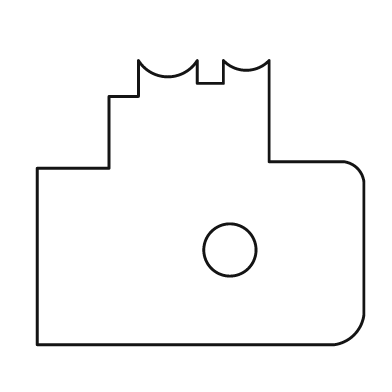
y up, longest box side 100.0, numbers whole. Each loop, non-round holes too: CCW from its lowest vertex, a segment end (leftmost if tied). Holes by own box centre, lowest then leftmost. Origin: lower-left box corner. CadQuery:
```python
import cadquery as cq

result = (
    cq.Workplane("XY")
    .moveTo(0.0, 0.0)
    .lineTo(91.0, 0.0)
    .threePointArc((97.0, 3.0), (100.0, 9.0))
    .lineTo(100.0, 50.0)
    .threePointArc((98.0, 54.0), (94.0, 56.0))
    .lineTo(71.0, 56.0)
    .lineTo(71.0, 87.0)
    .threePointArc((64.0, 84.0), (57.0, 87.0))
    .lineTo(57.0, 80.0)
    .lineTo(49.0, 80.0)
    .lineTo(49.0, 87.0)
    .threePointArc((40.0, 82.0), (31.0, 87.0))
    .lineTo(31.0, 76.0)
    .lineTo(22.0, 76.0)
    .lineTo(22.0, 54.0)
    .lineTo(0.0, 54.0)
    .close()
    .moveTo(59.0, 29.0)
    .circle(8.0)
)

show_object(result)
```